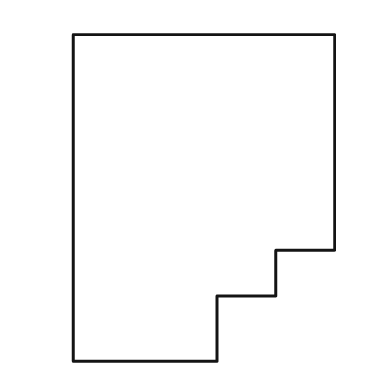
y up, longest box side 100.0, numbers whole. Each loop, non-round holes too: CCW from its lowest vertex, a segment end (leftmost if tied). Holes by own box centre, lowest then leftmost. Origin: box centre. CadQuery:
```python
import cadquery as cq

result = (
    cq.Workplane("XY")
    .moveTo(-40.0, -50.0)
    .lineTo(4.0, -50.0)
    .lineTo(4.0, -30.0)
    .lineTo(22.0, -30.0)
    .lineTo(22.0, -16.0)
    .lineTo(40.0, -16.0)
    .lineTo(40.0, 50.0)
    .lineTo(-40.0, 50.0)
    .close()
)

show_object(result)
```